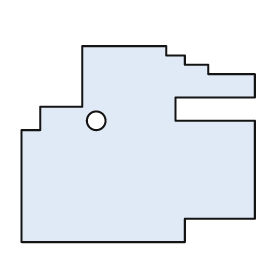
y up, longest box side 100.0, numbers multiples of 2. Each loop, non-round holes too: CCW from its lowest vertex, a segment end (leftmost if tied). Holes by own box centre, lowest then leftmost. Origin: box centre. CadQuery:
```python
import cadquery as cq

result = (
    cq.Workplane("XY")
    .moveTo(-50.0, -42.0)
    .lineTo(20.0, -42.0)
    .lineTo(20.0, -32.0)
    .lineTo(50.0, -32.0)
    .lineTo(50.0, 10.0)
    .lineTo(16.0, 10.0)
    .lineTo(16.0, 20.0)
    .lineTo(50.0, 20.0)
    .lineTo(50.0, 30.0)
    .lineTo(30.0, 30.0)
    .lineTo(30.0, 34.0)
    .lineTo(20.0, 34.0)
    .lineTo(20.0, 38.0)
    .lineTo(12.0, 38.0)
    .lineTo(12.0, 42.0)
    .lineTo(-24.0, 42.0)
    .lineTo(-24.0, 16.0)
    .lineTo(-42.0, 16.0)
    .lineTo(-42.0, 6.0)
    .lineTo(-50.0, 6.0)
    .close()
    .moveTo(-18.0, 10.0)
    .circle(4.0)
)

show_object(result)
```